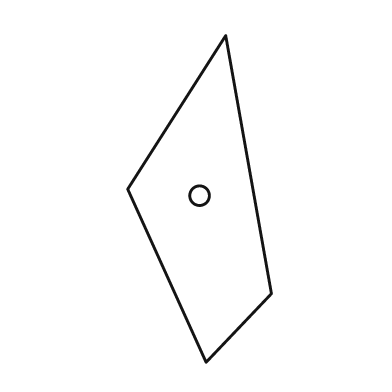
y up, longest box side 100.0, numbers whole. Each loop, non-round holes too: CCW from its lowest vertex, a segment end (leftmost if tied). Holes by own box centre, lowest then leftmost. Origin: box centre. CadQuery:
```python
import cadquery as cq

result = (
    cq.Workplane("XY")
    .moveTo(2.0, -50.0)
    .lineTo(22.0, -29.0)
    .lineTo(8.0, 50.0)
    .lineTo(-22.0, 3.0)
    .close()
    .moveTo(0.0, 1.0)
    .circle(3.0)
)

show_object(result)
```